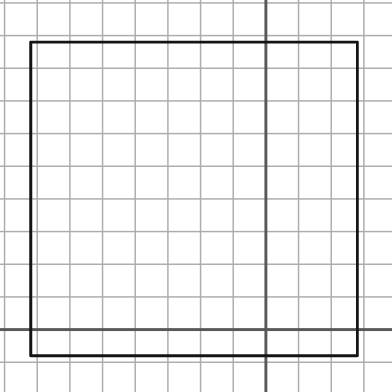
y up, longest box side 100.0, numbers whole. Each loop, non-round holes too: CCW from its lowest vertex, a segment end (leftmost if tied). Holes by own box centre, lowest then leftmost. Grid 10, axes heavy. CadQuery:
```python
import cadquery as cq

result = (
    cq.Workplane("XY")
    .moveTo(-72.0, -8.0)
    .lineTo(28.0, -8.0)
    .lineTo(28.0, 88.0)
    .lineTo(-72.0, 88.0)
    .close()
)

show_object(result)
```